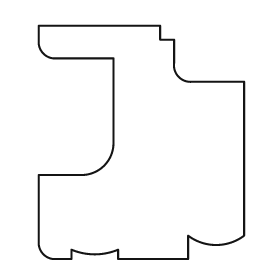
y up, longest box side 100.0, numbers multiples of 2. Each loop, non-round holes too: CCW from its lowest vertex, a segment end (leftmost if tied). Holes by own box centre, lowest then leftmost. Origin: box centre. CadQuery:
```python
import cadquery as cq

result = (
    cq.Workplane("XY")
    .moveTo(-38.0, -50.0)
    .lineTo(-30.0, -50.0)
    .lineTo(-30.0, -46.0)
    .threePointArc((-20.0, -48.0), (-10.0, -46.0))
    .lineTo(-10.0, -50.0)
    .lineTo(20.0, -50.0)
    .lineTo(20.0, -40.0)
    .threePointArc((32.0, -44.0), (44.0, -40.0))
    .lineTo(44.0, 26.0)
    .lineTo(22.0, 26.0)
    .threePointArc((16.0, 28.0), (14.0, 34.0))
    .lineTo(14.0, 44.0)
    .lineTo(8.0, 44.0)
    .lineTo(8.0, 50.0)
    .lineTo(-44.0, 50.0)
    .lineTo(-44.0, 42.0)
    .threePointArc((-42.0, 38.0), (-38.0, 36.0))
    .lineTo(-12.0, 36.0)
    .lineTo(-12.0, 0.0)
    .threePointArc((-16.0, -10.0), (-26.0, -14.0))
    .lineTo(-44.0, -14.0)
    .lineTo(-44.0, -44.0)
    .threePointArc((-42.0, -48.0), (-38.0, -50.0))
    .close()
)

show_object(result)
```